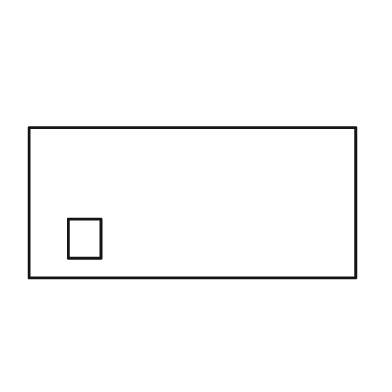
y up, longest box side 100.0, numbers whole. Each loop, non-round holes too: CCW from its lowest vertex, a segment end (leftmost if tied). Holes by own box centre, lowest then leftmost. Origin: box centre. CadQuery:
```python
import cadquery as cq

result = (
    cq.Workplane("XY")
    .moveTo(-50.0, -23.0)
    .lineTo(50.0, -23.0)
    .lineTo(50.0, 23.0)
    .lineTo(-50.0, 23.0)
    .close()
    .moveTo(-38.0, -17.0)
    .lineTo(-28.0, -17.0)
    .lineTo(-28.0, -5.0)
    .lineTo(-38.0, -5.0)
    .close()
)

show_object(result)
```